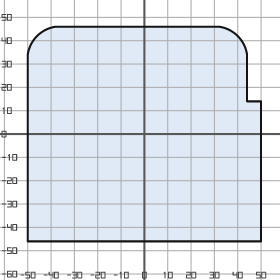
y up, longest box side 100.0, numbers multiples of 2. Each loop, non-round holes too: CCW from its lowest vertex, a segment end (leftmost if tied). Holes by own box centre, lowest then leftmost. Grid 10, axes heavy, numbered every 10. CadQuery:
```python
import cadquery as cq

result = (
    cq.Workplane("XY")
    .moveTo(-50.0, -46.0)
    .lineTo(50.0, -46.0)
    .lineTo(50.0, 14.0)
    .lineTo(44.0, 14.0)
    .lineTo(44.0, 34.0)
    .threePointArc((40.0, 42.0), (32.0, 46.0))
    .lineTo(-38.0, 46.0)
    .threePointArc((-46.0, 42.0), (-50.0, 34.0))
    .close()
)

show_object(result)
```